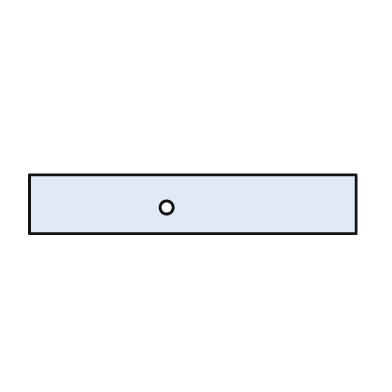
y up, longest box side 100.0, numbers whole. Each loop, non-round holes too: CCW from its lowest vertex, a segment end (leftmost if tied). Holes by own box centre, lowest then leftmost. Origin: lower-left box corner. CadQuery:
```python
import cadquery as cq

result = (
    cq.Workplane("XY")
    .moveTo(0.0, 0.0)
    .lineTo(100.0, 0.0)
    .lineTo(100.0, 18.0)
    .lineTo(0.0, 18.0)
    .close()
    .moveTo(42.0, 8.0)
    .circle(2.0)
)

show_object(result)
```